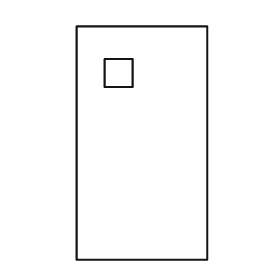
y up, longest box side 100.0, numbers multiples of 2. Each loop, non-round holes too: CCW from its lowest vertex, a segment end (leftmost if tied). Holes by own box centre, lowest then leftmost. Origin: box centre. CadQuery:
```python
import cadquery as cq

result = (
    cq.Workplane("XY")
    .moveTo(-28.0, -50.0)
    .lineTo(28.0, -50.0)
    .lineTo(28.0, 50.0)
    .lineTo(-28.0, 50.0)
    .close()
    .moveTo(-16.0, 24.0)
    .lineTo(-4.0, 24.0)
    .lineTo(-4.0, 36.0)
    .lineTo(-16.0, 36.0)
    .close()
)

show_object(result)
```